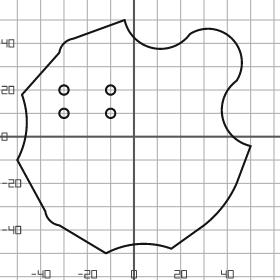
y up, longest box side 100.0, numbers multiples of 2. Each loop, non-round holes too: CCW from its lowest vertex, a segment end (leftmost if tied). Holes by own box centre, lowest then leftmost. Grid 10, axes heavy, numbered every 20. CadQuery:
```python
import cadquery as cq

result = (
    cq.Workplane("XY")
    .moveTo(-12.0, -50.0)
    .threePointArc((2.0, -46.0), (16.0, -48.0))
    .lineTo(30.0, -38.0)
    .threePointArc((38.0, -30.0), (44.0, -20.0))
    .lineTo(50.0, -4.0)
    .threePointArc((38.0, 8.0), (44.0, 24.0))
    .threePointArc((42.0, 42.0), (24.0, 44.0))
    .threePointArc((8.0, 38.0), (-4.0, 50.0))
    .lineTo(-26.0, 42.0)
    .threePointArc((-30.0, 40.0), (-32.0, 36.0))
    .lineTo(-48.0, 18.0)
    .threePointArc((-46.0, 4.0), (-50.0, -10.0))
    .lineTo(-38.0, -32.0)
    .threePointArc((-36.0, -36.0), (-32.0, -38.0))
    .close()
    .moveTo(-30.0, 10.0)
    .circle(2.0)
    .moveTo(-10.0, 10.0)
    .circle(2.0)
    .moveTo(-30.0, 20.0)
    .circle(2.0)
    .moveTo(-10.0, 20.0)
    .circle(2.0)
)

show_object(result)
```